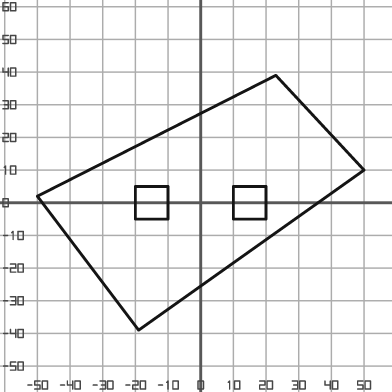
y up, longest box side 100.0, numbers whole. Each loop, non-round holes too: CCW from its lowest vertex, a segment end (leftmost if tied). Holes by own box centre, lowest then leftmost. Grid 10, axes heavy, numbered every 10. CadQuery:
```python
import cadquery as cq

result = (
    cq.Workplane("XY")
    .moveTo(-19.0, -39.0)
    .lineTo(50.0, 10.0)
    .lineTo(23.0, 39.0)
    .lineTo(-50.0, 2.0)
    .close()
    .moveTo(-20.0, -5.0)
    .lineTo(-10.0, -5.0)
    .lineTo(-10.0, 5.0)
    .lineTo(-20.0, 5.0)
    .close()
    .moveTo(10.0, -5.0)
    .lineTo(20.0, -5.0)
    .lineTo(20.0, 5.0)
    .lineTo(10.0, 5.0)
    .close()
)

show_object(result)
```